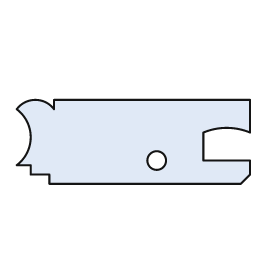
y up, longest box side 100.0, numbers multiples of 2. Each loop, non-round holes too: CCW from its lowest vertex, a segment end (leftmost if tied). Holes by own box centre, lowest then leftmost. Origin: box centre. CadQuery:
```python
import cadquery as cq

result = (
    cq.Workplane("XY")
    .moveTo(-36.0, -18.0)
    .lineTo(46.0, -18.0)
    .lineTo(50.0, -14.0)
    .lineTo(50.0, -8.0)
    .lineTo(30.0, -8.0)
    .lineTo(30.0, 4.0)
    .threePointArc((40.0, 6.0), (50.0, 4.0))
    .lineTo(50.0, 18.0)
    .lineTo(-34.0, 18.0)
    .lineTo(-34.0, 14.0)
    .threePointArc((-42.0, 18.0), (-50.0, 14.0))
    .threePointArc((-44.0, 2.0), (-50.0, -10.0))
    .lineTo(-44.0, -10.0)
    .lineTo(-44.0, -14.0)
    .lineTo(-36.0, -14.0)
    .close()
    .moveTo(10.0, -8.0)
    .circle(4.0)
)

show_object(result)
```